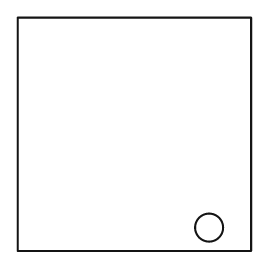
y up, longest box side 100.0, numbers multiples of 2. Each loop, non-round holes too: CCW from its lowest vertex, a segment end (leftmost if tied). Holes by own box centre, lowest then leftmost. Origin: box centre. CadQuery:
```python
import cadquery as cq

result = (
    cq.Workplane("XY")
    .moveTo(-50.0, -50.0)
    .lineTo(50.0, -50.0)
    .lineTo(50.0, 50.0)
    .lineTo(-50.0, 50.0)
    .close()
    .moveTo(32.0, -40.0)
    .circle(6.0)
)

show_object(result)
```